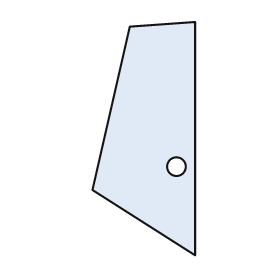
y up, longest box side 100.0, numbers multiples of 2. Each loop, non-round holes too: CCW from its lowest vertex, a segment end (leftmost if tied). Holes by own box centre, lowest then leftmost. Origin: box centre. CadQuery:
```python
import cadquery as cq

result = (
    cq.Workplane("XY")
    .moveTo(22.0, -50.0)
    .lineTo(22.0, 50.0)
    .lineTo(-6.0, 48.0)
    .lineTo(-22.0, -22.0)
    .close()
    .moveTo(14.0, -12.0)
    .circle(4.0)
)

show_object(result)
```